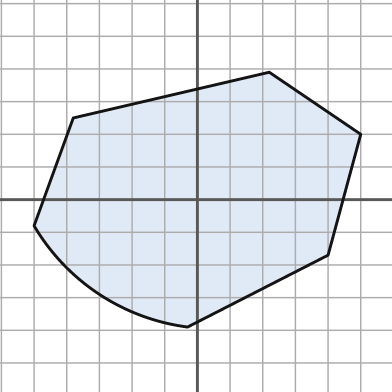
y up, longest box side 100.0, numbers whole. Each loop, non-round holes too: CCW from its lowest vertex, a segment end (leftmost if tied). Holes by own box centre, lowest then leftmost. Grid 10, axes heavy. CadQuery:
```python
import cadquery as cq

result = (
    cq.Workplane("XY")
    .moveTo(-3.0, -39.0)
    .lineTo(40.0, -17.0)
    .lineTo(50.0, 20.0)
    .lineTo(22.0, 39.0)
    .lineTo(-38.0, 25.0)
    .lineTo(-50.0, -8.0)
    .threePointArc((-30.0, -29.0), (-3.0, -39.0))
    .close()
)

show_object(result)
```